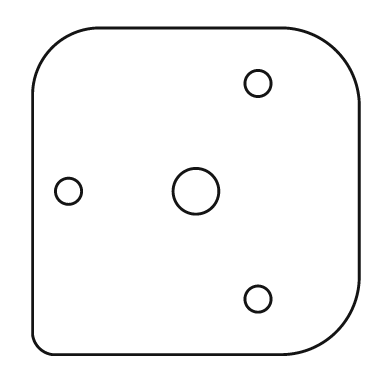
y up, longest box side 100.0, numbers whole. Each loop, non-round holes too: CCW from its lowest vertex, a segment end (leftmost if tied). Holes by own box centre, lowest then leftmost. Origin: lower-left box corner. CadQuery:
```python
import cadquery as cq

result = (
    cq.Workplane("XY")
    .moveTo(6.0, 0.0)
    .lineTo(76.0, 0.0)
    .threePointArc((93.0, 7.0), (100.0, 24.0))
    .lineTo(100.0, 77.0)
    .threePointArc((93.0, 93.0), (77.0, 100.0))
    .lineTo(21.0, 100.0)
    .threePointArc((6.0, 94.0), (0.0, 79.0))
    .lineTo(0.0, 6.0)
    .threePointArc((2.0, 2.0), (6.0, 0.0))
    .close()
    .moveTo(69.0, 17.0)
    .circle(4.0)
    .moveTo(11.0, 50.0)
    .circle(4.0)
    .moveTo(50.0, 50.0)
    .circle(7.0)
    .moveTo(69.0, 83.0)
    .circle(4.0)
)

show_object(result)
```